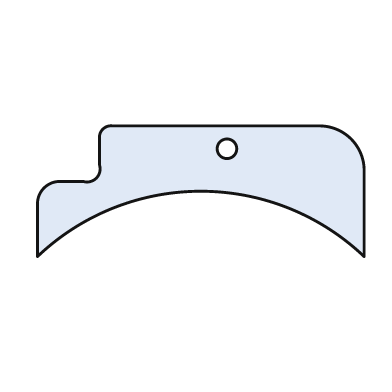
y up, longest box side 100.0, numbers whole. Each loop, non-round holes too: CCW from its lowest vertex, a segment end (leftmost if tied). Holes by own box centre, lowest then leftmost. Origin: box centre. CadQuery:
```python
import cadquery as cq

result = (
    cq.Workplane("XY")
    .moveTo(-50.0, -20.0)
    .threePointArc((0.0, 0.0), (50.0, -20.0))
    .lineTo(50.0, 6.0)
    .threePointArc((46.0, 16.0), (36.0, 20.0))
    .lineTo(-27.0, 20.0)
    .threePointArc((-30.0, 19.0), (-31.0, 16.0))
    .lineTo(-31.0, 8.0)
    .threePointArc((-32.0, 4.0), (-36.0, 3.0))
    .lineTo(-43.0, 3.0)
    .threePointArc((-48.0, 1.0), (-50.0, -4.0))
    .close()
    .moveTo(8.0, 13.0)
    .circle(3.0)
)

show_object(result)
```